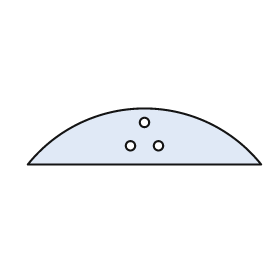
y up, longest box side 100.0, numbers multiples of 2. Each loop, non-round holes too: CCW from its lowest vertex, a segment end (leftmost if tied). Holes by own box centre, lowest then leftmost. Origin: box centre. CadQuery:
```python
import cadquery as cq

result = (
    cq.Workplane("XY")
    .moveTo(-50.0, -12.0)
    .lineTo(50.0, -12.0)
    .threePointArc((0.0, 12.0), (-50.0, -12.0))
    .close()
    .moveTo(-6.0, -4.0)
    .circle(2.0)
    .moveTo(6.0, -4.0)
    .circle(2.0)
    .moveTo(0.0, 6.0)
    .circle(2.0)
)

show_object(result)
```